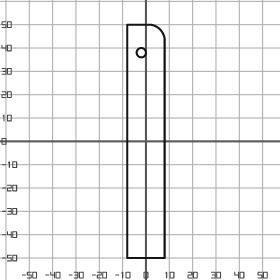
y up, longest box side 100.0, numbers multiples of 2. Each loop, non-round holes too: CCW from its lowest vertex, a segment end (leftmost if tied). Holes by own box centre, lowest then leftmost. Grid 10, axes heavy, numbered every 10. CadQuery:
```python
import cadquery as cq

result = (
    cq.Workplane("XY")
    .moveTo(-8.0, -50.0)
    .lineTo(8.0, -50.0)
    .lineTo(8.0, 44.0)
    .threePointArc((6.0, 48.0), (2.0, 50.0))
    .lineTo(-8.0, 50.0)
    .close()
    .moveTo(-2.0, 38.0)
    .circle(2.0)
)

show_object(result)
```